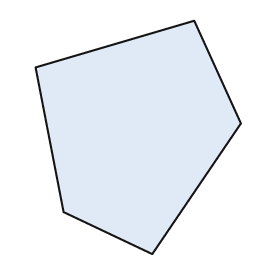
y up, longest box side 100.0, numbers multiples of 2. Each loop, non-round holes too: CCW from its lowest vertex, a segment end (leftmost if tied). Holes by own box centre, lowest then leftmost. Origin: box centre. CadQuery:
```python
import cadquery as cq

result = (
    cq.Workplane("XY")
    .moveTo(6.0, -50.0)
    .lineTo(44.0, 6.0)
    .lineTo(24.0, 50.0)
    .lineTo(-44.0, 30.0)
    .lineTo(-32.0, -32.0)
    .close()
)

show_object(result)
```